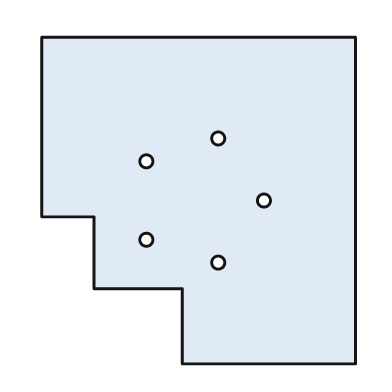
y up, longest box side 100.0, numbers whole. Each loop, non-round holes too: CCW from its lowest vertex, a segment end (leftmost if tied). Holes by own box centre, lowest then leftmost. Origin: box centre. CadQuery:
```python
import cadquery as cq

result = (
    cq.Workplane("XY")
    .moveTo(-5.0, -50.0)
    .lineTo(48.0, -50.0)
    .lineTo(48.0, 50.0)
    .lineTo(-48.0, 50.0)
    .lineTo(-48.0, -5.0)
    .lineTo(-32.0, -5.0)
    .lineTo(-32.0, -27.0)
    .lineTo(-5.0, -27.0)
    .close()
    .moveTo(6.0, -19.0)
    .circle(2.0)
    .moveTo(-16.0, -12.0)
    .circle(2.0)
    .moveTo(20.0, 0.0)
    .circle(2.0)
    .moveTo(-16.0, 12.0)
    .circle(2.0)
    .moveTo(6.0, 19.0)
    .circle(2.0)
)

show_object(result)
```